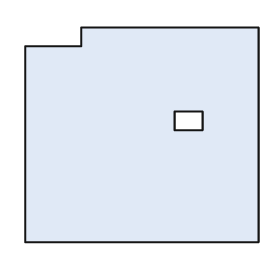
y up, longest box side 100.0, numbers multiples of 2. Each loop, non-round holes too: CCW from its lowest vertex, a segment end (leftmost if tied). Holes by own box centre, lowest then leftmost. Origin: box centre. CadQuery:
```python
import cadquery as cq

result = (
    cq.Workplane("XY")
    .moveTo(-50.0, -46.0)
    .lineTo(50.0, -46.0)
    .lineTo(50.0, 46.0)
    .lineTo(-26.0, 46.0)
    .lineTo(-26.0, 38.0)
    .lineTo(-50.0, 38.0)
    .close()
    .moveTo(14.0, 2.0)
    .lineTo(26.0, 2.0)
    .lineTo(26.0, 10.0)
    .lineTo(14.0, 10.0)
    .close()
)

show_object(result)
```